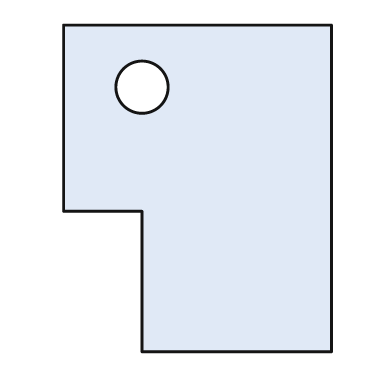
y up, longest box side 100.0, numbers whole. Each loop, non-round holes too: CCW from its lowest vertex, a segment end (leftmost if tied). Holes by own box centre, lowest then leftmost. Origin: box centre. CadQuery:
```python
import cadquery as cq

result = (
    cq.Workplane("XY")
    .moveTo(-17.0, -50.0)
    .lineTo(41.0, -50.0)
    .lineTo(41.0, 50.0)
    .lineTo(-41.0, 50.0)
    .lineTo(-41.0, -7.0)
    .lineTo(-17.0, -7.0)
    .close()
    .moveTo(-17.0, 31.0)
    .circle(8.0)
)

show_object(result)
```